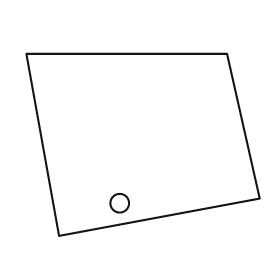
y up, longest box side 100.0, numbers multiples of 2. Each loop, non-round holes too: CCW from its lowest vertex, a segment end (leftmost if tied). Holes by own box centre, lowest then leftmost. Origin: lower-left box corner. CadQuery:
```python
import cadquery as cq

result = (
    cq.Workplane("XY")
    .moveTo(14.0, 0.0)
    .lineTo(100.0, 16.0)
    .lineTo(86.0, 78.0)
    .lineTo(0.0, 78.0)
    .close()
    .moveTo(40.0, 14.0)
    .circle(4.0)
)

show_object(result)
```